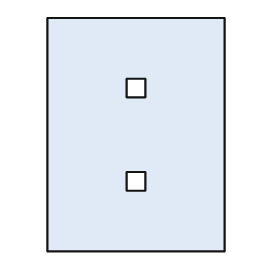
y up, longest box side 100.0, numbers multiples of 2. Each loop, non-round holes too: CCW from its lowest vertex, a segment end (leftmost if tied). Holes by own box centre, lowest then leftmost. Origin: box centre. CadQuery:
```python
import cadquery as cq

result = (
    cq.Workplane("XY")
    .moveTo(-38.0, -50.0)
    .lineTo(38.0, -50.0)
    .lineTo(38.0, 50.0)
    .lineTo(-38.0, 50.0)
    .close()
    .moveTo(-4.0, -24.0)
    .lineTo(4.0, -24.0)
    .lineTo(4.0, -16.0)
    .lineTo(-4.0, -16.0)
    .close()
    .moveTo(-4.0, 16.0)
    .lineTo(4.0, 16.0)
    .lineTo(4.0, 24.0)
    .lineTo(-4.0, 24.0)
    .close()
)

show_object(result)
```